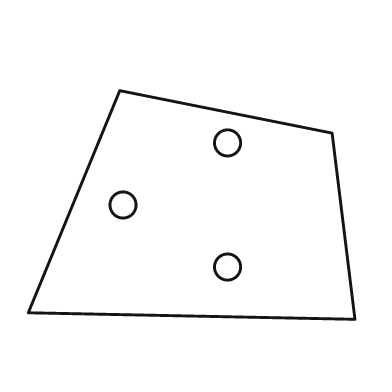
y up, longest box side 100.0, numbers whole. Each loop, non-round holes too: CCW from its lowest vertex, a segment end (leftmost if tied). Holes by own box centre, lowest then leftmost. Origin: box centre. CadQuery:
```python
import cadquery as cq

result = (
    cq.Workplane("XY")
    .moveTo(50.0, -35.0)
    .lineTo(43.0, 22.0)
    .lineTo(-22.0, 35.0)
    .lineTo(-50.0, -33.0)
    .close()
    .moveTo(11.0, -19.0)
    .circle(4.0)
    .moveTo(-21.0, 0.0)
    .circle(4.0)
    .moveTo(11.0, 19.0)
    .circle(4.0)
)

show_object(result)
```